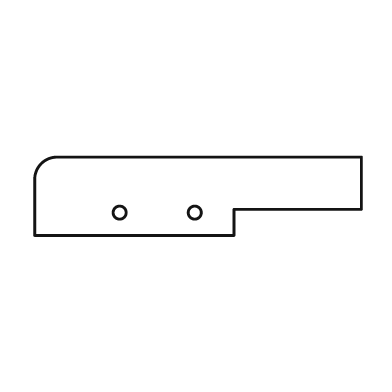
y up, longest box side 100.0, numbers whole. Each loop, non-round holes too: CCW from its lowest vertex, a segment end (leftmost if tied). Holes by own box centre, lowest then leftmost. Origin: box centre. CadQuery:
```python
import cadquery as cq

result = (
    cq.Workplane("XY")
    .moveTo(-50.0, -12.0)
    .lineTo(11.0, -12.0)
    .lineTo(11.0, -4.0)
    .lineTo(50.0, -4.0)
    .lineTo(50.0, 12.0)
    .lineTo(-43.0, 12.0)
    .threePointArc((-48.0, 10.0), (-50.0, 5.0))
    .close()
    .moveTo(-24.0, -5.0)
    .circle(2.0)
    .moveTo(-1.0, -5.0)
    .circle(2.0)
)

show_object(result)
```